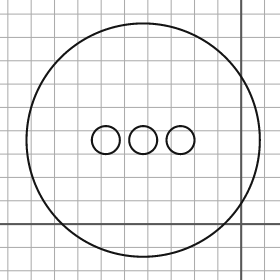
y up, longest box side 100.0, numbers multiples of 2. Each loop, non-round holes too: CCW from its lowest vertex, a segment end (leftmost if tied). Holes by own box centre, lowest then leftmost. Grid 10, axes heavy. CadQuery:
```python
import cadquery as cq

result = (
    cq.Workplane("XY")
    .moveTo(-42.0, 36.0)
    .circle(50.0)
    .moveTo(-58.0, 36.0)
    .circle(6.0)
    .moveTo(-42.0, 36.0)
    .circle(6.0)
    .moveTo(-26.0, 36.0)
    .circle(6.0)
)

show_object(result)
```